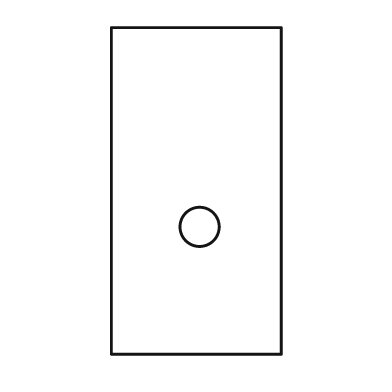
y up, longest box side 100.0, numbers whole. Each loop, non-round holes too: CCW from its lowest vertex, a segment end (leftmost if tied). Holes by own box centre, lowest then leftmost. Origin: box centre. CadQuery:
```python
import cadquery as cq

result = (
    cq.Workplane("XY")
    .moveTo(-26.0, -50.0)
    .lineTo(26.0, -50.0)
    .lineTo(26.0, 50.0)
    .lineTo(-26.0, 50.0)
    .close()
    .moveTo(1.0, -11.0)
    .circle(6.0)
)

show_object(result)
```